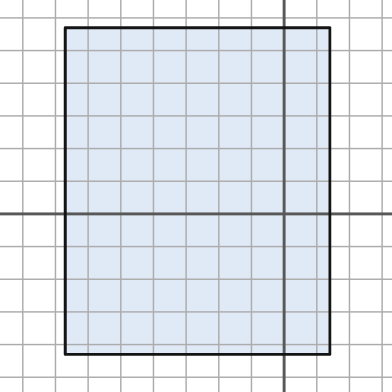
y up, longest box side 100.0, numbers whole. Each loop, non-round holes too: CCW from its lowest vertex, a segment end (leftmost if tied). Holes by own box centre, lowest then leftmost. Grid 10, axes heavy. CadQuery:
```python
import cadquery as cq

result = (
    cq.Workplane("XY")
    .moveTo(-67.0, -43.0)
    .lineTo(14.0, -43.0)
    .lineTo(14.0, 57.0)
    .lineTo(-67.0, 57.0)
    .close()
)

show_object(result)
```